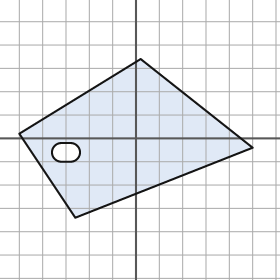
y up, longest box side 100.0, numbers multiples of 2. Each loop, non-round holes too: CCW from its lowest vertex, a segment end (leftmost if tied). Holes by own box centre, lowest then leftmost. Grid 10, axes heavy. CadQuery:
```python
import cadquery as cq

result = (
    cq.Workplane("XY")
    .moveTo(-26.0, -34.0)
    .lineTo(50.0, -4.0)
    .lineTo(2.0, 34.0)
    .lineTo(-50.0, 2.0)
    .close()
    .moveTo(-32.0, -10.0)
    .lineTo(-28.0, -10.0)
    .threePointArc((-24.0, -6.0), (-28.0, -2.0))
    .lineTo(-32.0, -2.0)
    .threePointArc((-36.0, -6.0), (-32.0, -10.0))
    .close()
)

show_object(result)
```